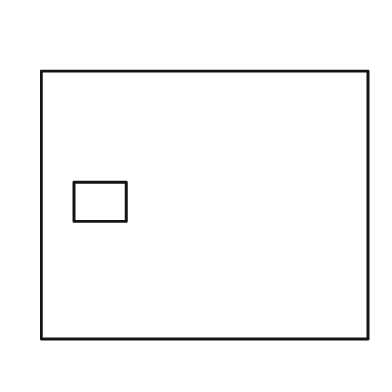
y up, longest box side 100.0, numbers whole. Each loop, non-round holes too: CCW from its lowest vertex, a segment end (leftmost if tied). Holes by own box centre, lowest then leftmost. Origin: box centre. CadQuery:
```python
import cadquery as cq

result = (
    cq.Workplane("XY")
    .moveTo(-50.0, -41.0)
    .lineTo(50.0, -41.0)
    .lineTo(50.0, 41.0)
    .lineTo(-50.0, 41.0)
    .close()
    .moveTo(-40.0, -5.0)
    .lineTo(-24.0, -5.0)
    .lineTo(-24.0, 7.0)
    .lineTo(-40.0, 7.0)
    .close()
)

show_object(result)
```